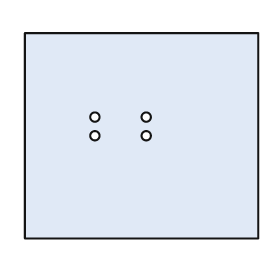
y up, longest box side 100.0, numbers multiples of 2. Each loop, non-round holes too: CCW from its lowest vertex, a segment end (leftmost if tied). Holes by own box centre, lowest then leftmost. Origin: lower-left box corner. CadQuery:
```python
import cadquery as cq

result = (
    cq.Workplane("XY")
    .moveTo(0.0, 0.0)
    .lineTo(100.0, 0.0)
    .lineTo(100.0, 88.0)
    .lineTo(0.0, 88.0)
    .close()
    .moveTo(30.0, 44.0)
    .circle(2.0)
    .moveTo(52.0, 44.0)
    .circle(2.0)
    .moveTo(30.0, 52.0)
    .circle(2.0)
    .moveTo(52.0, 52.0)
    .circle(2.0)
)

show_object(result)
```